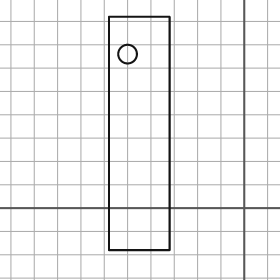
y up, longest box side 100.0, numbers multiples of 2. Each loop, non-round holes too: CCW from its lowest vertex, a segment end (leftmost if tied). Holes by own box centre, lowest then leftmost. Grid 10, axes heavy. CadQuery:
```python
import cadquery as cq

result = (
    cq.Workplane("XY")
    .moveTo(-58.0, -18.0)
    .lineTo(-32.0, -18.0)
    .lineTo(-32.0, 82.0)
    .lineTo(-58.0, 82.0)
    .close()
    .moveTo(-50.0, 66.0)
    .circle(4.0)
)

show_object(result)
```